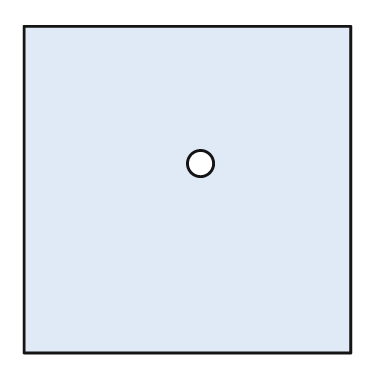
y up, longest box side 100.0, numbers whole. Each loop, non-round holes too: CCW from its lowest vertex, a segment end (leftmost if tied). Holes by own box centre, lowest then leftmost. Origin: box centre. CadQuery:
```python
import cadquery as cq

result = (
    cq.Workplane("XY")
    .moveTo(-50.0, -50.0)
    .lineTo(50.0, -50.0)
    .lineTo(50.0, 50.0)
    .lineTo(-50.0, 50.0)
    .close()
    .moveTo(4.0, 8.0)
    .circle(4.0)
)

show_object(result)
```